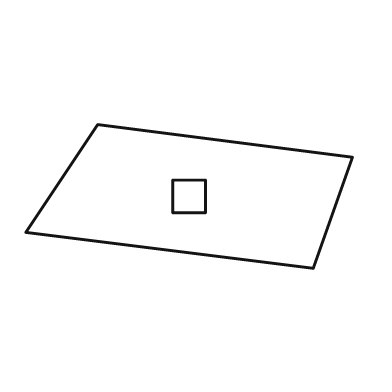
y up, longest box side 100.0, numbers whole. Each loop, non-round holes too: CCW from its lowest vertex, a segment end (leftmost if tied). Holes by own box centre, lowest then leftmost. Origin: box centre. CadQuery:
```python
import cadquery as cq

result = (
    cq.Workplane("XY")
    .moveTo(38.0, -22.0)
    .lineTo(50.0, 12.0)
    .lineTo(-28.0, 22.0)
    .lineTo(-50.0, -11.0)
    .close()
    .moveTo(-5.0, -5.0)
    .lineTo(5.0, -5.0)
    .lineTo(5.0, 5.0)
    .lineTo(-5.0, 5.0)
    .close()
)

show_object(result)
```